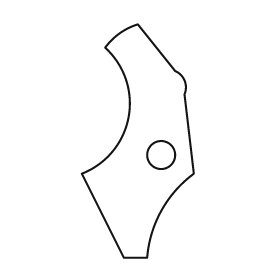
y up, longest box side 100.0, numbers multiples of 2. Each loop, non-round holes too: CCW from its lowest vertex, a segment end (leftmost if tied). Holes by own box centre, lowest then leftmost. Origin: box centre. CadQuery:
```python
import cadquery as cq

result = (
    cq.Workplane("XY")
    .moveTo(-6.0, -50.0)
    .lineTo(4.0, -50.0)
    .threePointArc((10.0, -30.0), (24.0, -14.0))
    .lineTo(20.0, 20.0)
    .threePointArc((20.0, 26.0), (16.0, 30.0))
    .lineTo(0.0, 50.0)
    .threePointArc((-8.0, 46.0), (-14.0, 40.0))
    .threePointArc((-4.0, 10.0), (-24.0, -14.0))
    .close()
    .moveTo(10.0, -6.0)
    .circle(6.0)
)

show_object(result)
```